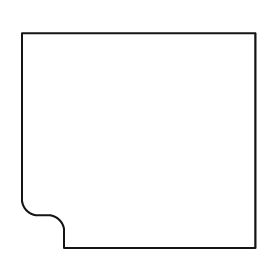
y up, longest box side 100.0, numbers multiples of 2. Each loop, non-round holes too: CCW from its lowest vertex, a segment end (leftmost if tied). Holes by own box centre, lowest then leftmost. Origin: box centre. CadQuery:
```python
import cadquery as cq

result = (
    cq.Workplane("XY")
    .moveTo(-32.0, -46.0)
    .lineTo(50.0, -46.0)
    .lineTo(50.0, 46.0)
    .lineTo(-50.0, 46.0)
    .lineTo(-50.0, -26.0)
    .threePointArc((-48.0, -30.0), (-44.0, -32.0))
    .lineTo(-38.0, -32.0)
    .threePointArc((-34.0, -34.0), (-32.0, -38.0))
    .close()
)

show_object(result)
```